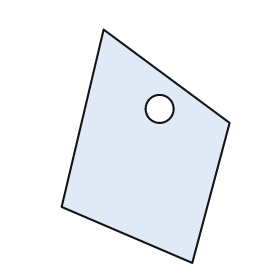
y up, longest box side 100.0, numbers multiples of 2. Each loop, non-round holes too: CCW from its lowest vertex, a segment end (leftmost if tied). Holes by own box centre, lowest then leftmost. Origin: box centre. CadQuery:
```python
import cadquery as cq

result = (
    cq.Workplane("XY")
    .moveTo(20.0, -50.0)
    .lineTo(36.0, 10.0)
    .lineTo(-18.0, 50.0)
    .lineTo(-36.0, -26.0)
    .close()
    .moveTo(6.0, 16.0)
    .circle(6.0)
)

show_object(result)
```